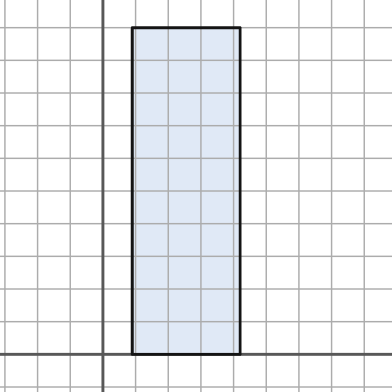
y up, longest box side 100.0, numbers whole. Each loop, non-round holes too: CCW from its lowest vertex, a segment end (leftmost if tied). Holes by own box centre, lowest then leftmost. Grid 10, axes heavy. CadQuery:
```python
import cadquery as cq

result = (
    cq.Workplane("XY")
    .moveTo(9.0, 0.0)
    .lineTo(42.0, 0.0)
    .lineTo(42.0, 100.0)
    .lineTo(9.0, 100.0)
    .close()
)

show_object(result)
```